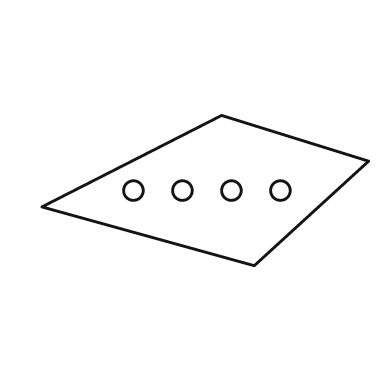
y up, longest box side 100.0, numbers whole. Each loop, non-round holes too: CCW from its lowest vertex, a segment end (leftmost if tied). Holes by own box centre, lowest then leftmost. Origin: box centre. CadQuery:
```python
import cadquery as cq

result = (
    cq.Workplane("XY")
    .moveTo(15.0, -23.0)
    .lineTo(50.0, 9.0)
    .lineTo(5.0, 23.0)
    .lineTo(-50.0, -5.0)
    .close()
    .moveTo(-22.0, 0.0)
    .circle(3.0)
    .moveTo(-7.0, 0.0)
    .circle(3.0)
    .moveTo(8.0, 0.0)
    .circle(3.0)
    .moveTo(23.0, 0.0)
    .circle(3.0)
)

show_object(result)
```